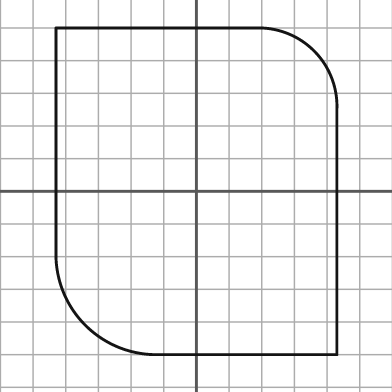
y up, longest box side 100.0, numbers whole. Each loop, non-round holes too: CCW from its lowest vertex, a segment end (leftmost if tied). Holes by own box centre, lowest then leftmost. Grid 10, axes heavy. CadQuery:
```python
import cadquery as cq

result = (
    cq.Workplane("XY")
    .moveTo(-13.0, -50.0)
    .lineTo(43.0, -50.0)
    .lineTo(43.0, 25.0)
    .threePointArc((36.0, 43.0), (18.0, 50.0))
    .lineTo(-43.0, 50.0)
    .lineTo(-43.0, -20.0)
    .threePointArc((-34.0, -41.0), (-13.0, -50.0))
    .close()
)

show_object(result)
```